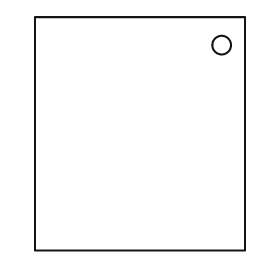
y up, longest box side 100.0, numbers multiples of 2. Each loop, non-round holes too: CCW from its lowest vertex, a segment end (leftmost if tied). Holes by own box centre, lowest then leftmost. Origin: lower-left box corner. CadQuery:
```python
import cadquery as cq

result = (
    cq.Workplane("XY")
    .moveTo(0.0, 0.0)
    .lineTo(90.0, 0.0)
    .lineTo(90.0, 100.0)
    .lineTo(0.0, 100.0)
    .close()
    .moveTo(80.0, 88.0)
    .circle(4.0)
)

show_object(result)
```